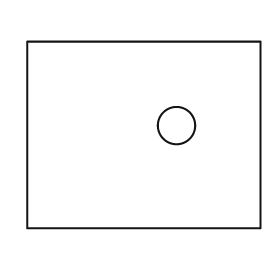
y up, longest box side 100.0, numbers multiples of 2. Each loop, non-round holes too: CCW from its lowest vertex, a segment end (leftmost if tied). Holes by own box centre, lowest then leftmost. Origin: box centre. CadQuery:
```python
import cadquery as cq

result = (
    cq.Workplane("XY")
    .moveTo(-50.0, -40.0)
    .lineTo(50.0, -40.0)
    .lineTo(50.0, 40.0)
    .lineTo(-50.0, 40.0)
    .close()
    .moveTo(14.0, 4.0)
    .circle(8.0)
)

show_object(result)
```